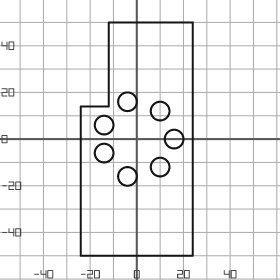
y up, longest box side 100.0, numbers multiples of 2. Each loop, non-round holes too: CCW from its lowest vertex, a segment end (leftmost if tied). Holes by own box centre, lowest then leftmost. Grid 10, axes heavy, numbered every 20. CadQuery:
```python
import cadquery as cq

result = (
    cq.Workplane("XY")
    .moveTo(-24.0, -50.0)
    .lineTo(24.0, -50.0)
    .lineTo(24.0, 50.0)
    .lineTo(-12.0, 50.0)
    .lineTo(-12.0, 14.0)
    .lineTo(-24.0, 14.0)
    .close()
    .moveTo(-4.0, -16.0)
    .circle(4.0)
    .moveTo(10.0, -12.0)
    .circle(4.0)
    .moveTo(-14.0, -6.0)
    .circle(4.0)
    .moveTo(16.0, 0.0)
    .circle(4.0)
    .moveTo(-14.0, 6.0)
    .circle(4.0)
    .moveTo(10.0, 12.0)
    .circle(4.0)
    .moveTo(-4.0, 16.0)
    .circle(4.0)
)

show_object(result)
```